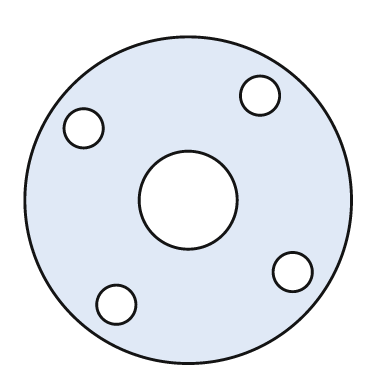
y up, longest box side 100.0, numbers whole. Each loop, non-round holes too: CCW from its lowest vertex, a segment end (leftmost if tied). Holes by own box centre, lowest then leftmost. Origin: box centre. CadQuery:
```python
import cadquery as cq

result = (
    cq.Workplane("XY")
    .moveTo(0.0, 0.0)
    .circle(50.0)
    .moveTo(-22.0, -32.0)
    .circle(6.0)
    .moveTo(32.0, -22.0)
    .circle(6.0)
    .moveTo(0.0, 0.0)
    .circle(15.0)
    .moveTo(-32.0, 22.0)
    .circle(6.0)
    .moveTo(22.0, 32.0)
    .circle(6.0)
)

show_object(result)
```